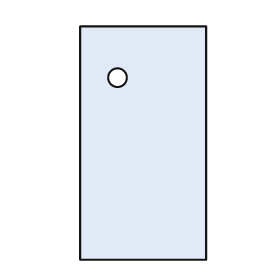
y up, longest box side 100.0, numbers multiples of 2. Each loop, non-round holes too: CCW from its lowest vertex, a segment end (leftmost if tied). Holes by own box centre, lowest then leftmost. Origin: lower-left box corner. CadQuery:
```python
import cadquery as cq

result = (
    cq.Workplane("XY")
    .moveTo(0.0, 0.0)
    .lineTo(54.0, 0.0)
    .lineTo(54.0, 100.0)
    .lineTo(0.0, 100.0)
    .close()
    .moveTo(16.0, 78.0)
    .circle(4.0)
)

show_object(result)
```